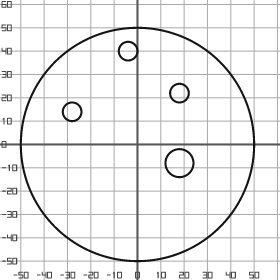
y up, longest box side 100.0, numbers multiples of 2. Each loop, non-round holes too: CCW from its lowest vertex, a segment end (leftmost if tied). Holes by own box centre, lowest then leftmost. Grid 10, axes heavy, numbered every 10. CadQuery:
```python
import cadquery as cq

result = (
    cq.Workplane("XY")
    .moveTo(0.0, 0.0)
    .circle(50.0)
    .moveTo(18.0, -8.0)
    .circle(6.0)
    .moveTo(-28.0, 14.0)
    .circle(4.0)
    .moveTo(18.0, 22.0)
    .circle(4.0)
    .moveTo(-4.0, 40.0)
    .circle(4.0)
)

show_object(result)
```